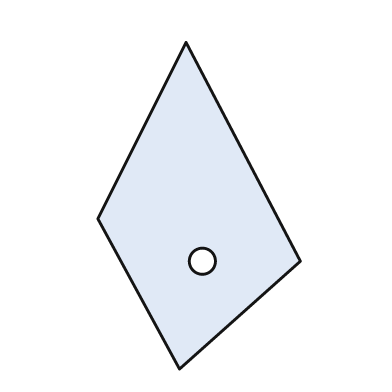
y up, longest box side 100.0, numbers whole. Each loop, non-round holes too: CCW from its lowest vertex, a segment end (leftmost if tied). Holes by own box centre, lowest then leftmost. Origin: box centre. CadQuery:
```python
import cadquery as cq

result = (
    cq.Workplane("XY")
    .moveTo(-6.0, -50.0)
    .lineTo(31.0, -17.0)
    .lineTo(-4.0, 50.0)
    .lineTo(-31.0, -4.0)
    .close()
    .moveTo(1.0, -17.0)
    .circle(4.0)
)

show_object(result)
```